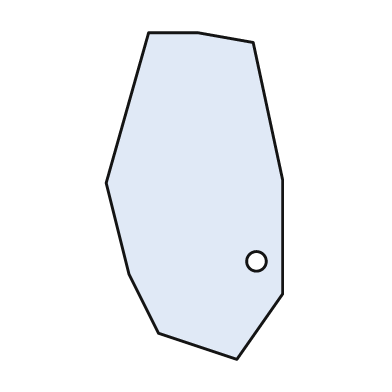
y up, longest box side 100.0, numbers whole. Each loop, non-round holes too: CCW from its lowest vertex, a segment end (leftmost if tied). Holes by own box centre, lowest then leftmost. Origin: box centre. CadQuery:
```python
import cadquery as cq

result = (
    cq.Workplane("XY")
    .moveTo(13.0, -50.0)
    .lineTo(27.0, -30.0)
    .lineTo(27.0, 5.0)
    .lineTo(18.0, 47.0)
    .lineTo(1.0, 50.0)
    .lineTo(-14.0, 50.0)
    .lineTo(-27.0, 4.0)
    .lineTo(-20.0, -24.0)
    .lineTo(-11.0, -42.0)
    .close()
    .moveTo(19.0, -20.0)
    .circle(3.0)
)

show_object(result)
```